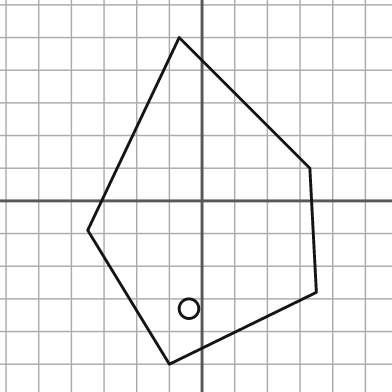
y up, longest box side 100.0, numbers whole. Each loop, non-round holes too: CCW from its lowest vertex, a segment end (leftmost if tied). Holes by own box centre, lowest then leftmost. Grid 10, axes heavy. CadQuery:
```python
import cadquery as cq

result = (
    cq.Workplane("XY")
    .moveTo(-10.0, -50.0)
    .lineTo(35.0, -28.0)
    .lineTo(33.0, 10.0)
    .lineTo(-7.0, 50.0)
    .lineTo(-35.0, -9.0)
    .close()
    .moveTo(-4.0, -33.0)
    .circle(3.0)
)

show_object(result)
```